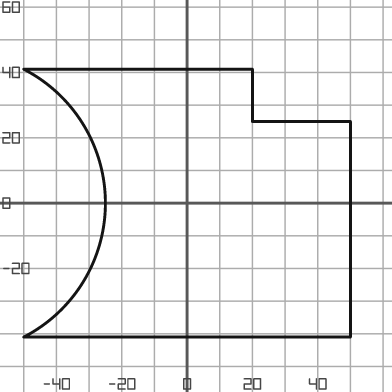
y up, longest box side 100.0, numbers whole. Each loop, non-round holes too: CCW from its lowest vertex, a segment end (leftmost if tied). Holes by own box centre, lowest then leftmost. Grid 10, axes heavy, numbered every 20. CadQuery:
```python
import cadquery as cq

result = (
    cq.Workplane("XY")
    .moveTo(-50.0, -41.0)
    .lineTo(50.0, -41.0)
    .lineTo(50.0, 25.0)
    .lineTo(20.0, 25.0)
    .lineTo(20.0, 41.0)
    .lineTo(-50.0, 41.0)
    .threePointArc((-25.0, 0.0), (-50.0, -41.0))
    .close()
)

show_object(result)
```